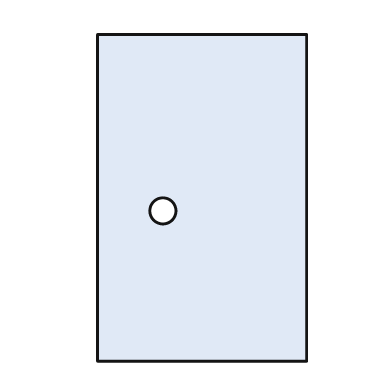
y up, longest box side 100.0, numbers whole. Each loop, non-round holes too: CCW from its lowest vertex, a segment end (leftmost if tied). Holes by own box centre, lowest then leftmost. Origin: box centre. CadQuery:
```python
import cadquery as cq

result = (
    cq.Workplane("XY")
    .moveTo(-32.0, -50.0)
    .lineTo(32.0, -50.0)
    .lineTo(32.0, 50.0)
    .lineTo(-32.0, 50.0)
    .close()
    .moveTo(-12.0, -4.0)
    .circle(4.0)
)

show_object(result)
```